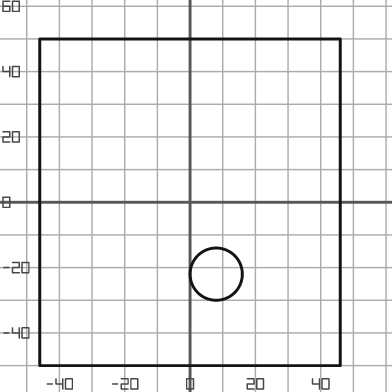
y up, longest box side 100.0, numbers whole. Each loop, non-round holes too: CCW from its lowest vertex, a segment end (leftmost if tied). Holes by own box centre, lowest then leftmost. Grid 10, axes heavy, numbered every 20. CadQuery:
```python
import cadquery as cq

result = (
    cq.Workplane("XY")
    .moveTo(-46.0, -50.0)
    .lineTo(46.0, -50.0)
    .lineTo(46.0, 50.0)
    .lineTo(-46.0, 50.0)
    .close()
    .moveTo(8.0, -22.0)
    .circle(8.0)
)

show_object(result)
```